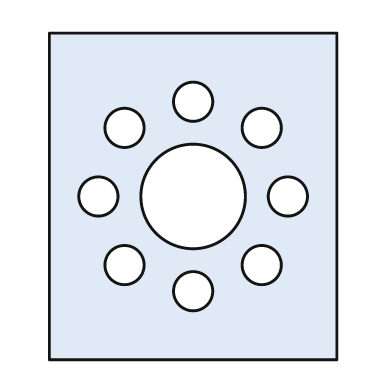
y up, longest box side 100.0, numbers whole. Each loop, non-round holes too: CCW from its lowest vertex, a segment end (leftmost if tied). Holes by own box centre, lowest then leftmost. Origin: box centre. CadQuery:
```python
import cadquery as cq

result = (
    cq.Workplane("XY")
    .moveTo(-44.0, -50.0)
    .lineTo(44.0, -50.0)
    .lineTo(44.0, 50.0)
    .lineTo(-44.0, 50.0)
    .close()
    .moveTo(0.0, -29.0)
    .circle(6.0)
    .moveTo(-21.0, -21.0)
    .circle(6.0)
    .moveTo(21.0, -21.0)
    .circle(6.0)
    .moveTo(-29.0, 0.0)
    .circle(6.0)
    .moveTo(0.0, 0.0)
    .circle(16.0)
    .moveTo(29.0, 0.0)
    .circle(6.0)
    .moveTo(-21.0, 21.0)
    .circle(6.0)
    .moveTo(21.0, 21.0)
    .circle(6.0)
    .moveTo(0.0, 29.0)
    .circle(6.0)
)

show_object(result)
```